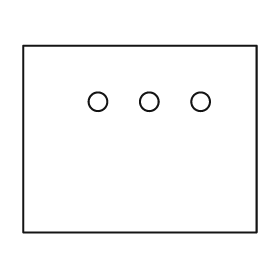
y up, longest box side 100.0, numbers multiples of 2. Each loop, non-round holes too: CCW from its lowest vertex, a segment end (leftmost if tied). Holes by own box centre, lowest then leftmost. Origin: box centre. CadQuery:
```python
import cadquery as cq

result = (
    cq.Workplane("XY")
    .moveTo(-50.0, -40.0)
    .lineTo(50.0, -40.0)
    .lineTo(50.0, 40.0)
    .lineTo(-50.0, 40.0)
    .close()
    .moveTo(-18.0, 16.0)
    .circle(4.0)
    .moveTo(4.0, 16.0)
    .circle(4.0)
    .moveTo(26.0, 16.0)
    .circle(4.0)
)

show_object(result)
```